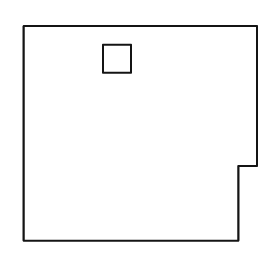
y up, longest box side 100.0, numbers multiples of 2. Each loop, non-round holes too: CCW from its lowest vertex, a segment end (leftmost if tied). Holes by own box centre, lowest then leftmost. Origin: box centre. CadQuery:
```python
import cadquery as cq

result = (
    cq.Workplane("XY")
    .moveTo(-50.0, -46.0)
    .lineTo(42.0, -46.0)
    .lineTo(42.0, -14.0)
    .lineTo(50.0, -14.0)
    .lineTo(50.0, 46.0)
    .lineTo(-50.0, 46.0)
    .close()
    .moveTo(-16.0, 26.0)
    .lineTo(-4.0, 26.0)
    .lineTo(-4.0, 38.0)
    .lineTo(-16.0, 38.0)
    .close()
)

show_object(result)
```